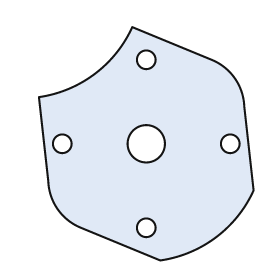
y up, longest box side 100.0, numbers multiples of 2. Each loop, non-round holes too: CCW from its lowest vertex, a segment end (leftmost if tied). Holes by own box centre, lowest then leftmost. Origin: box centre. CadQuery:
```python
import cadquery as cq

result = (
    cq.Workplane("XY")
    .moveTo(6.0, -50.0)
    .threePointArc((30.0, -40.0), (46.0, -20.0))
    .lineTo(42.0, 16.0)
    .threePointArc((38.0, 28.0), (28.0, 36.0))
    .lineTo(-6.0, 50.0)
    .threePointArc((-22.0, 30.0), (-46.0, 20.0))
    .lineTo(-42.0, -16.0)
    .threePointArc((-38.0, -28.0), (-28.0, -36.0))
    .close()
    .moveTo(0.0, -36.0)
    .circle(4.0)
    .moveTo(-36.0, 0.0)
    .circle(4.0)
    .moveTo(0.0, 0.0)
    .circle(8.0)
    .moveTo(36.0, 0.0)
    .circle(4.0)
    .moveTo(0.0, 36.0)
    .circle(4.0)
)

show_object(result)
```